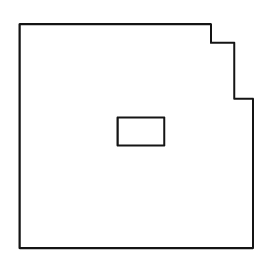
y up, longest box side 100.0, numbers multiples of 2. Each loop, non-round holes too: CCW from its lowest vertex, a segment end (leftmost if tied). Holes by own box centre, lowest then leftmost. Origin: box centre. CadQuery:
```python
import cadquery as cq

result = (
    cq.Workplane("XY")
    .moveTo(-50.0, -48.0)
    .lineTo(50.0, -48.0)
    .lineTo(50.0, 16.0)
    .lineTo(42.0, 16.0)
    .lineTo(42.0, 40.0)
    .lineTo(32.0, 40.0)
    .lineTo(32.0, 48.0)
    .lineTo(-50.0, 48.0)
    .close()
    .moveTo(-8.0, -4.0)
    .lineTo(12.0, -4.0)
    .lineTo(12.0, 8.0)
    .lineTo(-8.0, 8.0)
    .close()
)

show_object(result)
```